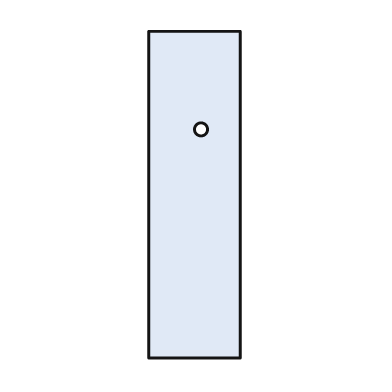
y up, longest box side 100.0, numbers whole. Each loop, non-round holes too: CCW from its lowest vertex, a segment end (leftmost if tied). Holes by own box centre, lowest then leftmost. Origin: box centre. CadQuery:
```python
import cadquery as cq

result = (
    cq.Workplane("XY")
    .moveTo(-14.0, -50.0)
    .lineTo(14.0, -50.0)
    .lineTo(14.0, 50.0)
    .lineTo(-14.0, 50.0)
    .close()
    .moveTo(2.0, 20.0)
    .circle(2.0)
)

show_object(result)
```